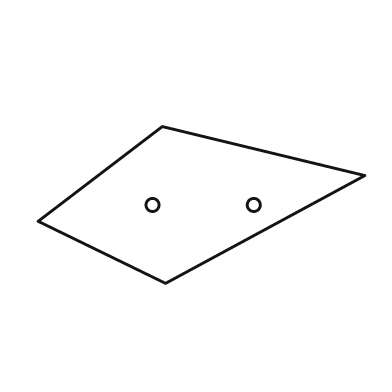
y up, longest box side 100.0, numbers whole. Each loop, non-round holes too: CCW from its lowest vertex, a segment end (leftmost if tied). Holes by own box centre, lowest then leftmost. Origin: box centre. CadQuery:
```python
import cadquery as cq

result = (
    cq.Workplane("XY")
    .moveTo(-11.0, -24.0)
    .lineTo(50.0, 9.0)
    .lineTo(-12.0, 24.0)
    .lineTo(-50.0, -5.0)
    .close()
    .moveTo(-15.0, 0.0)
    .circle(2.0)
    .moveTo(16.0, 0.0)
    .circle(2.0)
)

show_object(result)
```